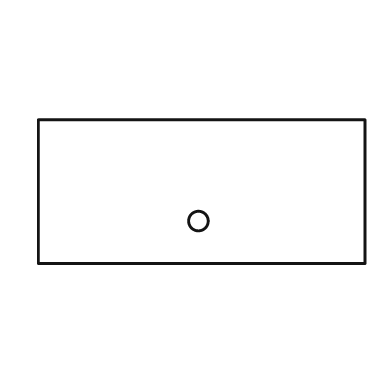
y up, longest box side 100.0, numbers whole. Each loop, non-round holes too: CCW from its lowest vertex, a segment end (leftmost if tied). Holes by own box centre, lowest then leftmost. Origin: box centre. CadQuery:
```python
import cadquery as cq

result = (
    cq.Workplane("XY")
    .moveTo(-50.0, -22.0)
    .lineTo(50.0, -22.0)
    .lineTo(50.0, 22.0)
    .lineTo(-50.0, 22.0)
    .close()
    .moveTo(-1.0, -9.0)
    .circle(3.0)
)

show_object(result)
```